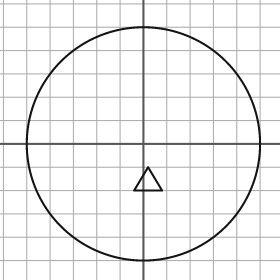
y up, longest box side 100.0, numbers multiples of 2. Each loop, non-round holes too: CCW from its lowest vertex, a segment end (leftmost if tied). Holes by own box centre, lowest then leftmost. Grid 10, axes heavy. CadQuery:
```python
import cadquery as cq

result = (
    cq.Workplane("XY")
    .moveTo(0.0, 0.0)
    .circle(50.0)
    .moveTo(-4.0, -20.0)
    .lineTo(8.0, -20.0)
    .lineTo(2.0, -10.0)
    .close()
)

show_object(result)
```